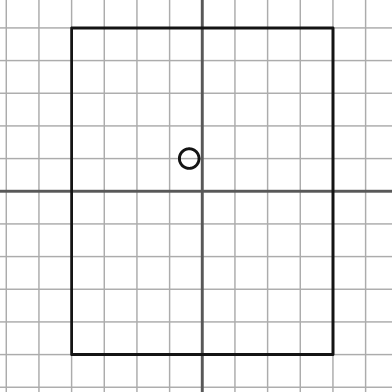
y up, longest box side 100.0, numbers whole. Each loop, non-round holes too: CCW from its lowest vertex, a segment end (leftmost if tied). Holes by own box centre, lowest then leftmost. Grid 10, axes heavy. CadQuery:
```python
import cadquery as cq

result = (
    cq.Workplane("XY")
    .moveTo(-40.0, -50.0)
    .lineTo(40.0, -50.0)
    .lineTo(40.0, 50.0)
    .lineTo(-40.0, 50.0)
    .close()
    .moveTo(-4.0, 10.0)
    .circle(3.0)
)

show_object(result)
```